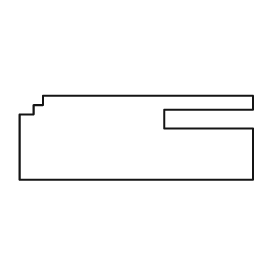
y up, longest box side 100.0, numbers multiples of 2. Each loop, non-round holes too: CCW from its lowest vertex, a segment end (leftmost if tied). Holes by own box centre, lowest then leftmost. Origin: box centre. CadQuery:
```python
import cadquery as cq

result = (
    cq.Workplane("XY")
    .moveTo(-50.0, -18.0)
    .lineTo(50.0, -18.0)
    .lineTo(50.0, 4.0)
    .lineTo(12.0, 4.0)
    .lineTo(12.0, 12.0)
    .lineTo(50.0, 12.0)
    .lineTo(50.0, 18.0)
    .lineTo(-40.0, 18.0)
    .lineTo(-40.0, 14.0)
    .lineTo(-44.0, 14.0)
    .lineTo(-44.0, 10.0)
    .lineTo(-50.0, 10.0)
    .close()
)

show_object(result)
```